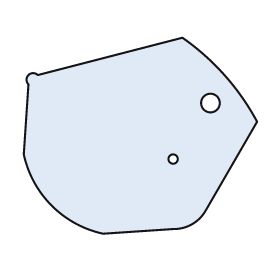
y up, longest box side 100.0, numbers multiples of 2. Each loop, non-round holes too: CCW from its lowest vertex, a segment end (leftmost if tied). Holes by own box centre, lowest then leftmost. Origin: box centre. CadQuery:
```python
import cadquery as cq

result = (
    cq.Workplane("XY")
    .moveTo(-16.0, -42.0)
    .lineTo(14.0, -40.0)
    .threePointArc((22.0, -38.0), (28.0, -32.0))
    .lineTo(50.0, 6.0)
    .threePointArc((36.0, 26.0), (18.0, 42.0))
    .lineTo(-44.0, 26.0)
    .threePointArc((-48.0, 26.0), (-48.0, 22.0))
    .lineTo(-50.0, -8.0)
    .threePointArc((-38.0, -30.0), (-16.0, -42.0))
    .close()
    .moveTo(14.0, -10.0)
    .circle(2.0)
    .moveTo(30.0, 14.0)
    .circle(4.0)
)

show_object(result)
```